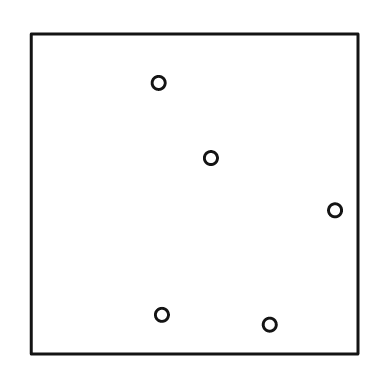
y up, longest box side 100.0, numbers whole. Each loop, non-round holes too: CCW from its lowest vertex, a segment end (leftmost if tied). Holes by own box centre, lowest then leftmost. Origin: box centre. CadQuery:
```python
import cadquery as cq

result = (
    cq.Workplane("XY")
    .moveTo(-50.0, -49.0)
    .lineTo(50.0, -49.0)
    .lineTo(50.0, 49.0)
    .lineTo(-50.0, 49.0)
    .close()
    .moveTo(23.0, -40.0)
    .circle(2.0)
    .moveTo(-10.0, -37.0)
    .circle(2.0)
    .moveTo(43.0, -5.0)
    .circle(2.0)
    .moveTo(5.0, 11.0)
    .circle(2.0)
    .moveTo(-11.0, 34.0)
    .circle(2.0)
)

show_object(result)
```